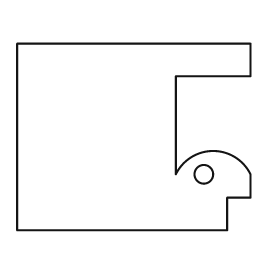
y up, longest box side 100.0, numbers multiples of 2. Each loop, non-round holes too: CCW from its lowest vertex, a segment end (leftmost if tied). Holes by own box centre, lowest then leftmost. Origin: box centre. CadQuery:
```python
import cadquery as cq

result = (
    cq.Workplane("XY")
    .moveTo(-50.0, -40.0)
    .lineTo(40.0, -40.0)
    .lineTo(40.0, -26.0)
    .lineTo(50.0, -26.0)
    .lineTo(50.0, -16.0)
    .threePointArc((34.0, -6.0), (18.0, -16.0))
    .lineTo(18.0, 26.0)
    .lineTo(50.0, 26.0)
    .lineTo(50.0, 40.0)
    .lineTo(-50.0, 40.0)
    .close()
    .moveTo(30.0, -16.0)
    .circle(4.0)
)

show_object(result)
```